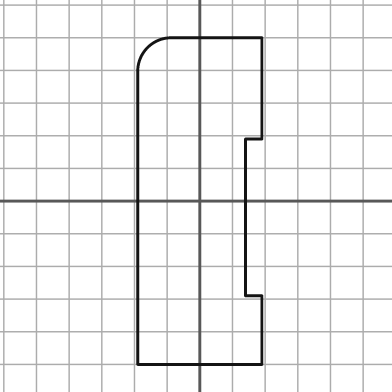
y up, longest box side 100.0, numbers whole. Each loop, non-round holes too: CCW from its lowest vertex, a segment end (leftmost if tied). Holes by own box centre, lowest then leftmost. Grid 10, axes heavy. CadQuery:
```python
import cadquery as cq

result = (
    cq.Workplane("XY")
    .moveTo(-19.0, -50.0)
    .lineTo(19.0, -50.0)
    .lineTo(19.0, -29.0)
    .lineTo(14.0, -29.0)
    .lineTo(14.0, 19.0)
    .lineTo(19.0, 19.0)
    .lineTo(19.0, 50.0)
    .lineTo(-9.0, 50.0)
    .threePointArc((-16.0, 47.0), (-19.0, 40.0))
    .close()
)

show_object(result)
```